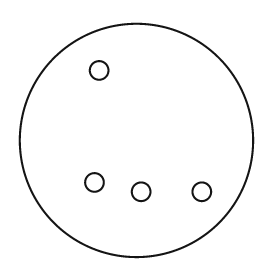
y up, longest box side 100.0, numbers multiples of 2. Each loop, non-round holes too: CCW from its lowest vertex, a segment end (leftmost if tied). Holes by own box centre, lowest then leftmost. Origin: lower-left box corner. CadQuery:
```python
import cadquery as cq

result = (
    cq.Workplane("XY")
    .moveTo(50.0, 50.0)
    .circle(50.0)
    .moveTo(52.0, 28.0)
    .circle(4.0)
    .moveTo(78.0, 28.0)
    .circle(4.0)
    .moveTo(32.0, 32.0)
    .circle(4.0)
    .moveTo(34.0, 80.0)
    .circle(4.0)
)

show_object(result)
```